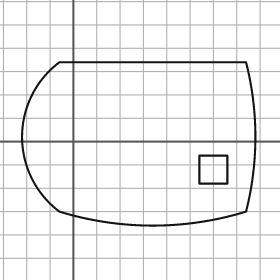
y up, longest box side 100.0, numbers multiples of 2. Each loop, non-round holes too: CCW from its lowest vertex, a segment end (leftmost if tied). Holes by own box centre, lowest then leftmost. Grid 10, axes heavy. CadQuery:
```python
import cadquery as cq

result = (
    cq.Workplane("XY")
    .moveTo(-6.0, -30.0)
    .threePointArc((34.0, -36.0), (74.0, -30.0))
    .threePointArc((78.0, 2.0), (74.0, 34.0))
    .lineTo(-6.0, 34.0)
    .threePointArc((-22.0, 2.0), (-6.0, -30.0))
    .close()
    .moveTo(54.0, -18.0)
    .lineTo(66.0, -18.0)
    .lineTo(66.0, -6.0)
    .lineTo(54.0, -6.0)
    .close()
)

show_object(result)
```